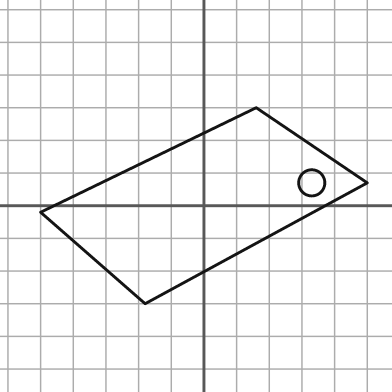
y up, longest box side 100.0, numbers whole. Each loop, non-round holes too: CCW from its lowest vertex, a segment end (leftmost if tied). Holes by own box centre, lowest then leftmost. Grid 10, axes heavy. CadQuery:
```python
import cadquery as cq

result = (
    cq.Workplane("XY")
    .moveTo(-18.0, -30.0)
    .lineTo(50.0, 7.0)
    .lineTo(16.0, 30.0)
    .lineTo(-50.0, -2.0)
    .close()
    .moveTo(33.0, 7.0)
    .circle(4.0)
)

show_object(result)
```